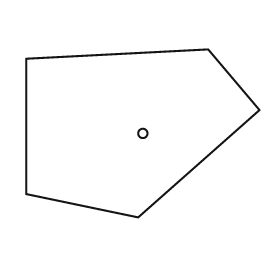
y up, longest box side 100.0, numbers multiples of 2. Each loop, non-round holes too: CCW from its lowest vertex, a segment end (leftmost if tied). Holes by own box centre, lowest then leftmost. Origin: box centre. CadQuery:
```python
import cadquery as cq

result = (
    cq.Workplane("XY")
    .moveTo(-2.0, -36.0)
    .lineTo(50.0, 10.0)
    .lineTo(28.0, 36.0)
    .lineTo(-50.0, 32.0)
    .lineTo(-50.0, -26.0)
    .close()
    .moveTo(0.0, 0.0)
    .circle(2.0)
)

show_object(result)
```